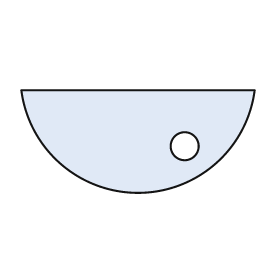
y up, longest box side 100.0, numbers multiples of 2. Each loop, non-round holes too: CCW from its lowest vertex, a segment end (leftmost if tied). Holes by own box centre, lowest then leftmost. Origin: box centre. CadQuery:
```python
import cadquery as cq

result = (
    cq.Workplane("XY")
    .moveTo(-50.0, 22.0)
    .threePointArc((0.0, -22.0), (50.0, 22.0))
    .close()
    .moveTo(20.0, -2.0)
    .circle(6.0)
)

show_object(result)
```